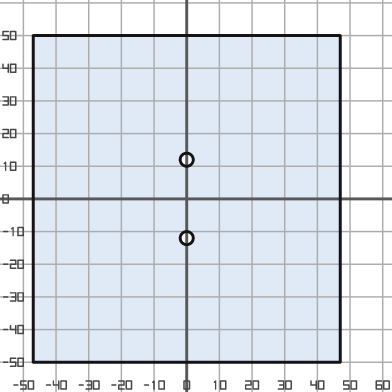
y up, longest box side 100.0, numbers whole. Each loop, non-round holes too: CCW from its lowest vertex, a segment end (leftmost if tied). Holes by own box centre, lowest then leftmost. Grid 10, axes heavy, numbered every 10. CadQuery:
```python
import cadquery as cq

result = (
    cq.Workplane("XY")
    .moveTo(-47.0, -50.0)
    .lineTo(47.0, -50.0)
    .lineTo(47.0, 50.0)
    .lineTo(-47.0, 50.0)
    .close()
    .moveTo(0.0, -12.0)
    .circle(2.0)
    .moveTo(0.0, 12.0)
    .circle(2.0)
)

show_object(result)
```